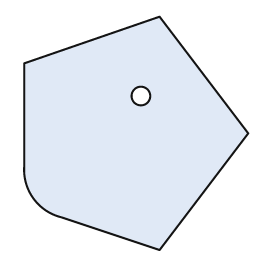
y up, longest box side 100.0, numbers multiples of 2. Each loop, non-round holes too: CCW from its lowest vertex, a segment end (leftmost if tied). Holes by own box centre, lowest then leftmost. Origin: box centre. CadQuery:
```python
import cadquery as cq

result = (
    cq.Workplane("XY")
    .moveTo(10.0, -50.0)
    .lineTo(48.0, 0.0)
    .lineTo(10.0, 50.0)
    .lineTo(-48.0, 30.0)
    .lineTo(-48.0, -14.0)
    .threePointArc((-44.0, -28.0), (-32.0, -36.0))
    .close()
    .moveTo(2.0, 16.0)
    .circle(4.0)
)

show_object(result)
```